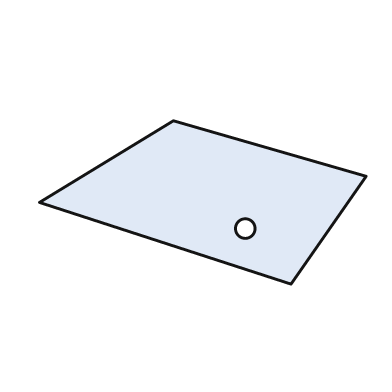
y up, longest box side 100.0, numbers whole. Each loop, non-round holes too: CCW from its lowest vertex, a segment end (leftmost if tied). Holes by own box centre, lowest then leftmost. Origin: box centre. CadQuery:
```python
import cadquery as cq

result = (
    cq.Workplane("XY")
    .moveTo(27.0, -25.0)
    .lineTo(50.0, 8.0)
    .lineTo(-9.0, 25.0)
    .lineTo(-50.0, 0.0)
    .close()
    .moveTo(13.0, -8.0)
    .circle(3.0)
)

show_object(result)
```